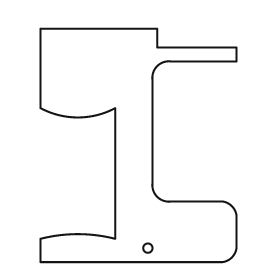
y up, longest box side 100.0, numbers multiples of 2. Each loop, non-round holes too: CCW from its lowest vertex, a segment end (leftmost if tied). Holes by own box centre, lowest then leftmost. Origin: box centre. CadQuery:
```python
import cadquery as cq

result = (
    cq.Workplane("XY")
    .moveTo(-42.0, -50.0)
    .lineTo(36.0, -50.0)
    .threePointArc((40.0, -48.0), (42.0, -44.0))
    .lineTo(42.0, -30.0)
    .threePointArc((40.0, -26.0), (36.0, -24.0))
    .lineTo(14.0, -24.0)
    .threePointArc((8.0, -22.0), (6.0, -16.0))
    .lineTo(6.0, 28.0)
    .threePointArc((8.0, 34.0), (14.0, 36.0))
    .lineTo(42.0, 36.0)
    .lineTo(42.0, 42.0)
    .lineTo(8.0, 42.0)
    .lineTo(8.0, 50.0)
    .lineTo(-42.0, 50.0)
    .lineTo(-42.0, 16.0)
    .threePointArc((-26.0, 12.0), (-10.0, 16.0))
    .lineTo(-10.0, -40.0)
    .threePointArc((-26.0, -38.0), (-42.0, -40.0))
    .close()
    .moveTo(4.0, -44.0)
    .circle(2.0)
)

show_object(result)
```